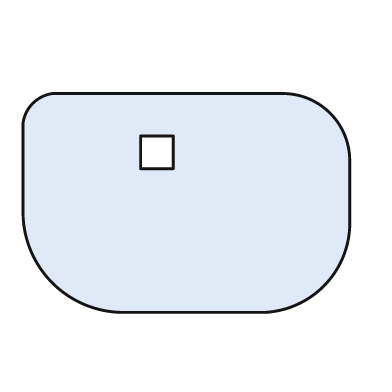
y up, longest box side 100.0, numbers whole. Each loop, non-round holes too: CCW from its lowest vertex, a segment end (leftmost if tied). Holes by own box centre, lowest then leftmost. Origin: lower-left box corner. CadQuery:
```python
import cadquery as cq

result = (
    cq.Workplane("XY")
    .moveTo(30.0, 0.0)
    .lineTo(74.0, 0.0)
    .threePointArc((92.0, 8.0), (100.0, 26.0))
    .lineTo(100.0, 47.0)
    .threePointArc((94.0, 61.0), (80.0, 67.0))
    .lineTo(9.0, 67.0)
    .threePointArc((3.0, 64.0), (0.0, 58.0))
    .lineTo(0.0, 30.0)
    .threePointArc((9.0, 9.0), (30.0, 0.0))
    .close()
    .moveTo(36.0, 44.0)
    .lineTo(46.0, 44.0)
    .lineTo(46.0, 54.0)
    .lineTo(36.0, 54.0)
    .close()
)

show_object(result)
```